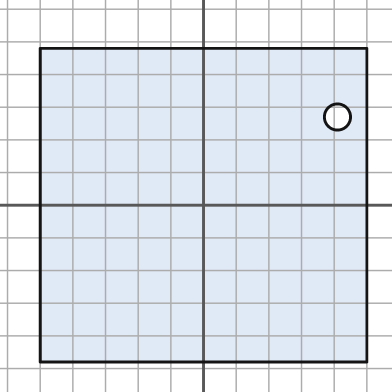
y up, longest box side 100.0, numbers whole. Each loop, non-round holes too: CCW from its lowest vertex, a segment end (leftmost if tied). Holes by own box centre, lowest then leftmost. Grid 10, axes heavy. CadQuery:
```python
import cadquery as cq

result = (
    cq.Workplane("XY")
    .moveTo(-50.0, -48.0)
    .lineTo(50.0, -48.0)
    .lineTo(50.0, 48.0)
    .lineTo(-50.0, 48.0)
    .close()
    .moveTo(41.0, 27.0)
    .circle(4.0)
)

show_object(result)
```